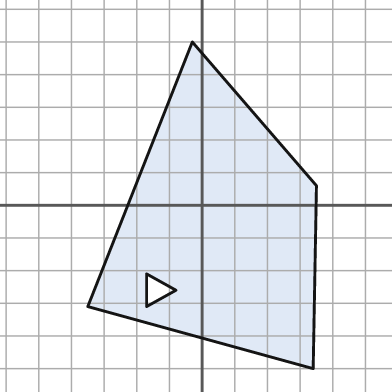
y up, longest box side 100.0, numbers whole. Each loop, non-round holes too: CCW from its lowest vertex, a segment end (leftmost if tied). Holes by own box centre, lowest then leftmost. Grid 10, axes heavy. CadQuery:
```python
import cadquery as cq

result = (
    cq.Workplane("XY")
    .moveTo(34.0, -50.0)
    .lineTo(35.0, 6.0)
    .lineTo(-3.0, 50.0)
    .lineTo(-35.0, -31.0)
    .close()
    .moveTo(-17.0, -31.0)
    .lineTo(-8.0, -26.0)
    .lineTo(-17.0, -21.0)
    .close()
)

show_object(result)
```